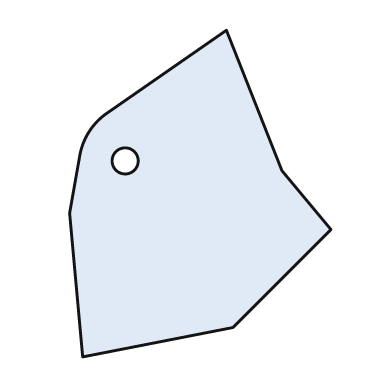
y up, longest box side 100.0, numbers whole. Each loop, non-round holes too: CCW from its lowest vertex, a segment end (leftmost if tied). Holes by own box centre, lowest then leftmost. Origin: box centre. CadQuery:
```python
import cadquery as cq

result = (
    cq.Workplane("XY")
    .moveTo(-36.0, -50.0)
    .lineTo(10.0, -41.0)
    .lineTo(40.0, -11.0)
    .lineTo(25.0, 7.0)
    .lineTo(8.0, 50.0)
    .lineTo(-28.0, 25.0)
    .threePointArc((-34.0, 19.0), (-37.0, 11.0))
    .lineTo(-40.0, -6.0)
    .close()
    .moveTo(-23.0, 10.0)
    .circle(4.0)
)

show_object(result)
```